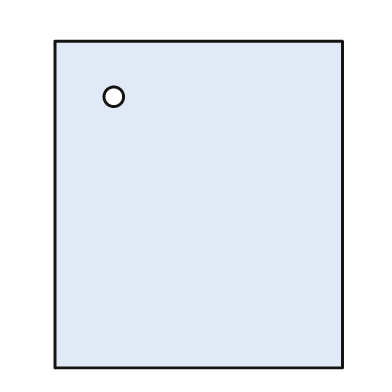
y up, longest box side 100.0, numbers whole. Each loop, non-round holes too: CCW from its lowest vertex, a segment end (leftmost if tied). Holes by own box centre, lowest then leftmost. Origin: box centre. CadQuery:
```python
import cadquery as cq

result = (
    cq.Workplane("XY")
    .moveTo(-44.0, -50.0)
    .lineTo(44.0, -50.0)
    .lineTo(44.0, 50.0)
    .lineTo(-44.0, 50.0)
    .close()
    .moveTo(-26.0, 33.0)
    .circle(3.0)
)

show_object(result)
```